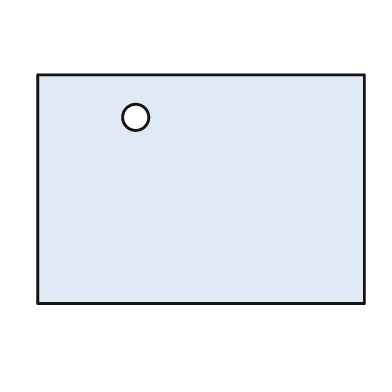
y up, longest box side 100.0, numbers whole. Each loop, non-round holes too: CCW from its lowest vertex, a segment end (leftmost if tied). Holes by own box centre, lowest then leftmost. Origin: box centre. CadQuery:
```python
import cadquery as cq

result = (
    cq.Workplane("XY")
    .moveTo(-50.0, -35.0)
    .lineTo(50.0, -35.0)
    .lineTo(50.0, 35.0)
    .lineTo(-50.0, 35.0)
    .close()
    .moveTo(-20.0, 22.0)
    .circle(4.0)
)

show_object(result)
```